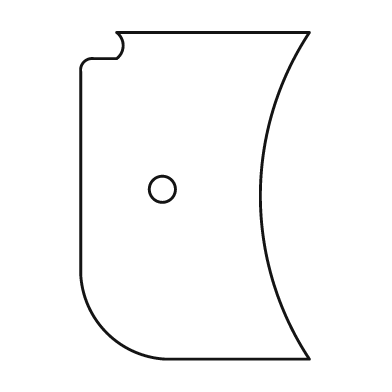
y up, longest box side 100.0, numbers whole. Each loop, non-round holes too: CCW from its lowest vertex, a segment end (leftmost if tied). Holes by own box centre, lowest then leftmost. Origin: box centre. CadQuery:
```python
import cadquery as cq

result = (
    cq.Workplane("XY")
    .moveTo(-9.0, -50.0)
    .lineTo(35.0, -50.0)
    .threePointArc((20.0, 0.0), (35.0, 50.0))
    .lineTo(-24.0, 50.0)
    .threePointArc((-22.0, 46.0), (-24.0, 42.0))
    .lineTo(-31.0, 42.0)
    .threePointArc((-34.0, 41.0), (-35.0, 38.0))
    .lineTo(-35.0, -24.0)
    .threePointArc((-27.0, -42.0), (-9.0, -50.0))
    .close()
    .moveTo(-10.0, 2.0)
    .circle(4.0)
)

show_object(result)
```